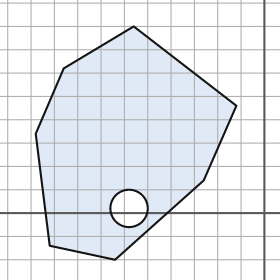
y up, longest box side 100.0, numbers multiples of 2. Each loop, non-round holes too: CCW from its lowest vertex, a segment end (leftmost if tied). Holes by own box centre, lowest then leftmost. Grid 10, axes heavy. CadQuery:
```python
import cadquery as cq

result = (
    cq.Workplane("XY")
    .moveTo(-64.0, -20.0)
    .lineTo(-26.0, 14.0)
    .lineTo(-12.0, 46.0)
    .lineTo(-56.0, 80.0)
    .lineTo(-86.0, 62.0)
    .lineTo(-98.0, 34.0)
    .lineTo(-92.0, -14.0)
    .close()
    .moveTo(-58.0, 2.0)
    .circle(8.0)
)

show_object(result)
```